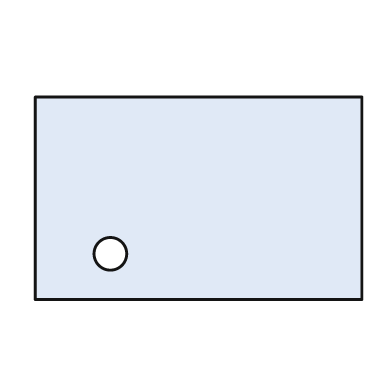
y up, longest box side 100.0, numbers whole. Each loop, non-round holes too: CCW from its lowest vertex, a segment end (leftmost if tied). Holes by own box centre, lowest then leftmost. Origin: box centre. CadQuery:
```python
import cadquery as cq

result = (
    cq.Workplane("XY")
    .moveTo(-50.0, -31.0)
    .lineTo(50.0, -31.0)
    .lineTo(50.0, 31.0)
    .lineTo(-50.0, 31.0)
    .close()
    .moveTo(-27.0, -17.0)
    .circle(5.0)
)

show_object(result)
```